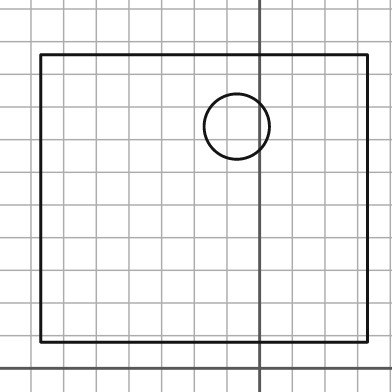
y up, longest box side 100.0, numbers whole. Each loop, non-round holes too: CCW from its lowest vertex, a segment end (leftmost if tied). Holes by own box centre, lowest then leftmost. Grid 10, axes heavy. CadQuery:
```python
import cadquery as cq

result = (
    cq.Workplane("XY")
    .moveTo(-67.0, 8.0)
    .lineTo(33.0, 8.0)
    .lineTo(33.0, 96.0)
    .lineTo(-67.0, 96.0)
    .close()
    .moveTo(-7.0, 74.0)
    .circle(10.0)
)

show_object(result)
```